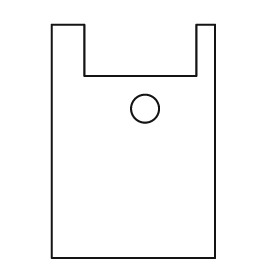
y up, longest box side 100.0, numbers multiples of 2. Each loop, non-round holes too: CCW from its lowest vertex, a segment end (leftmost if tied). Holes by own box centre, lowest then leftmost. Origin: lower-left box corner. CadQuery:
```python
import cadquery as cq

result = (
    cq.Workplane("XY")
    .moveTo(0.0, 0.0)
    .lineTo(70.0, 0.0)
    .lineTo(70.0, 100.0)
    .lineTo(62.0, 100.0)
    .lineTo(62.0, 78.0)
    .lineTo(14.0, 78.0)
    .lineTo(14.0, 100.0)
    .lineTo(0.0, 100.0)
    .close()
    .moveTo(40.0, 64.0)
    .circle(6.0)
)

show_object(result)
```